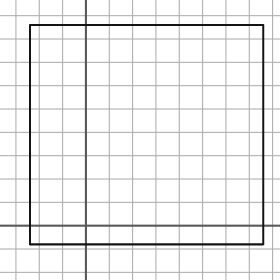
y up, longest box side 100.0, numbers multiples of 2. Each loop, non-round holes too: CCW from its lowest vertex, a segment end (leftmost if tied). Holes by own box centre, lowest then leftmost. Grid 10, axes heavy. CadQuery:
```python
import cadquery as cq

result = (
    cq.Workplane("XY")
    .moveTo(-24.0, -8.0)
    .lineTo(76.0, -8.0)
    .lineTo(76.0, 86.0)
    .lineTo(-24.0, 86.0)
    .close()
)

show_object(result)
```